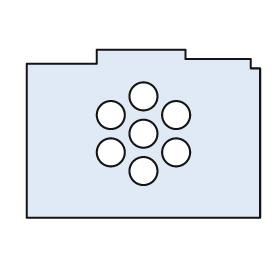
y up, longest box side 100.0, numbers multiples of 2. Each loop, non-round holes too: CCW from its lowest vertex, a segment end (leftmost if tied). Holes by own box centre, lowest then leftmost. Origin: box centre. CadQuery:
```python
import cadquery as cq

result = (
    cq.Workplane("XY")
    .moveTo(-50.0, -36.0)
    .lineTo(50.0, -36.0)
    .lineTo(50.0, 28.0)
    .lineTo(46.0, 28.0)
    .lineTo(46.0, 32.0)
    .lineTo(18.0, 32.0)
    .lineTo(18.0, 36.0)
    .lineTo(-20.0, 36.0)
    .lineTo(-20.0, 30.0)
    .lineTo(-50.0, 30.0)
    .close()
    .moveTo(0.0, -16.0)
    .circle(6.0)
    .moveTo(-14.0, -8.0)
    .circle(6.0)
    .moveTo(14.0, -8.0)
    .circle(6.0)
    .moveTo(0.0, 0.0)
    .circle(6.0)
    .moveTo(-14.0, 8.0)
    .circle(6.0)
    .moveTo(14.0, 8.0)
    .circle(6.0)
    .moveTo(0.0, 16.0)
    .circle(6.0)
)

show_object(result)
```